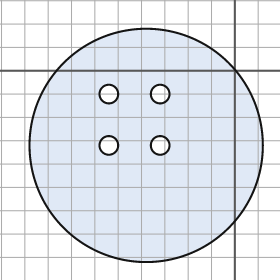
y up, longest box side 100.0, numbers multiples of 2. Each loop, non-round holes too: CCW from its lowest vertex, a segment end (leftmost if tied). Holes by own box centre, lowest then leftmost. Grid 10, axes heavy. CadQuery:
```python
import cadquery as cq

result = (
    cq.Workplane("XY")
    .moveTo(-38.0, -32.0)
    .circle(50.0)
    .moveTo(-54.0, -32.0)
    .circle(4.0)
    .moveTo(-32.0, -32.0)
    .circle(4.0)
    .moveTo(-54.0, -10.0)
    .circle(4.0)
    .moveTo(-32.0, -10.0)
    .circle(4.0)
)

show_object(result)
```